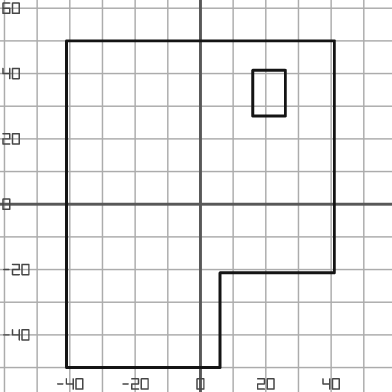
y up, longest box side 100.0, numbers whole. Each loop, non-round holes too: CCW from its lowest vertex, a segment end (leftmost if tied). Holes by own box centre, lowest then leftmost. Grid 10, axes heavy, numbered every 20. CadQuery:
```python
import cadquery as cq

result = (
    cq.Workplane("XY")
    .moveTo(-41.0, -50.0)
    .lineTo(6.0, -50.0)
    .lineTo(6.0, -21.0)
    .lineTo(41.0, -21.0)
    .lineTo(41.0, 50.0)
    .lineTo(-41.0, 50.0)
    .close()
    .moveTo(16.0, 27.0)
    .lineTo(26.0, 27.0)
    .lineTo(26.0, 41.0)
    .lineTo(16.0, 41.0)
    .close()
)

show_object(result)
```